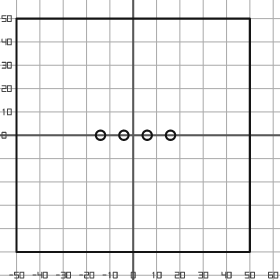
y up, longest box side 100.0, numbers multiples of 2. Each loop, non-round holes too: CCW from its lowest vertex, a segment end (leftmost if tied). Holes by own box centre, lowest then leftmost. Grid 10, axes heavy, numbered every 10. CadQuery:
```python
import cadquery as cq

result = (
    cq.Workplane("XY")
    .moveTo(-50.0, -50.0)
    .lineTo(50.0, -50.0)
    .lineTo(50.0, 50.0)
    .lineTo(-50.0, 50.0)
    .close()
    .moveTo(-14.0, 0.0)
    .circle(2.0)
    .moveTo(-4.0, 0.0)
    .circle(2.0)
    .moveTo(6.0, 0.0)
    .circle(2.0)
    .moveTo(16.0, 0.0)
    .circle(2.0)
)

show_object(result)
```